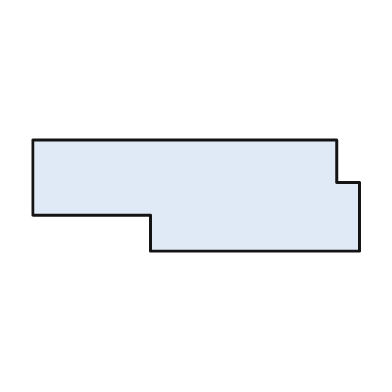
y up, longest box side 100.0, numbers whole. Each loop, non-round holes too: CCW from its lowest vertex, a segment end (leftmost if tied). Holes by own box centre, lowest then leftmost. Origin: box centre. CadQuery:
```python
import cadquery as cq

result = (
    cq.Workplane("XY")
    .moveTo(-14.0, -17.0)
    .lineTo(50.0, -17.0)
    .lineTo(50.0, 4.0)
    .lineTo(43.0, 4.0)
    .lineTo(43.0, 17.0)
    .lineTo(-50.0, 17.0)
    .lineTo(-50.0, -6.0)
    .lineTo(-14.0, -6.0)
    .close()
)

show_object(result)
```